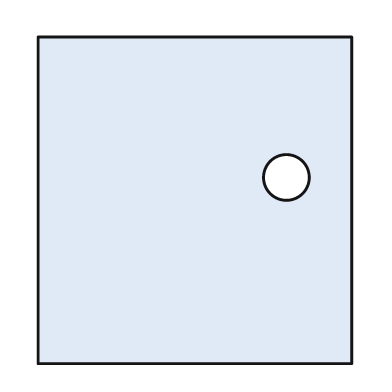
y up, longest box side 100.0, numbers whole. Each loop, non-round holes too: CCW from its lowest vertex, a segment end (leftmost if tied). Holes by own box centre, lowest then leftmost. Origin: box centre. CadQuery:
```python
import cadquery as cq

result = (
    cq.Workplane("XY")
    .moveTo(-48.0, -50.0)
    .lineTo(48.0, -50.0)
    .lineTo(48.0, 50.0)
    .lineTo(-48.0, 50.0)
    .close()
    .moveTo(28.0, 7.0)
    .circle(7.0)
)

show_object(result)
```